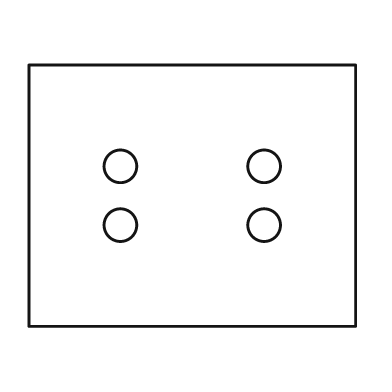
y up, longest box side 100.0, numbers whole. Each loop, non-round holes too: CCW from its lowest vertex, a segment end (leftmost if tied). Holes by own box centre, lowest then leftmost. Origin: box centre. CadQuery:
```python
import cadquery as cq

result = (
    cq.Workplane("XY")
    .moveTo(-50.0, -40.0)
    .lineTo(50.0, -40.0)
    .lineTo(50.0, 40.0)
    .lineTo(-50.0, 40.0)
    .close()
    .moveTo(-22.0, -9.0)
    .circle(5.0)
    .moveTo(22.0, -9.0)
    .circle(5.0)
    .moveTo(-22.0, 9.0)
    .circle(5.0)
    .moveTo(22.0, 9.0)
    .circle(5.0)
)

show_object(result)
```